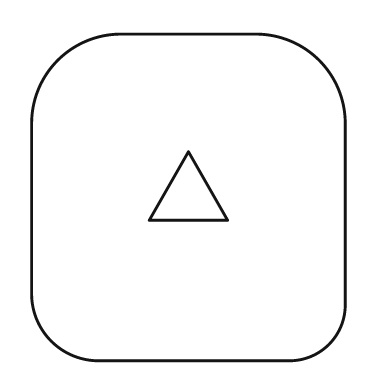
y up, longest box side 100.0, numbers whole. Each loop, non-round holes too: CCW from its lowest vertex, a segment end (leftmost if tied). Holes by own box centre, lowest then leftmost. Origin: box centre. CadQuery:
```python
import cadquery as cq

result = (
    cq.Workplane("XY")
    .moveTo(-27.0, -50.0)
    .lineTo(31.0, -50.0)
    .threePointArc((43.0, -45.0), (48.0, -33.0))
    .lineTo(48.0, 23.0)
    .threePointArc((40.0, 42.0), (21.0, 50.0))
    .lineTo(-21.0, 50.0)
    .threePointArc((-40.0, 42.0), (-48.0, 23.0))
    .lineTo(-48.0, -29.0)
    .threePointArc((-42.0, -44.0), (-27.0, -50.0))
    .close()
    .moveTo(-12.0, -7.0)
    .lineTo(12.0, -7.0)
    .lineTo(0.0, 14.0)
    .close()
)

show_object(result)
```